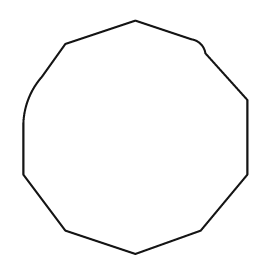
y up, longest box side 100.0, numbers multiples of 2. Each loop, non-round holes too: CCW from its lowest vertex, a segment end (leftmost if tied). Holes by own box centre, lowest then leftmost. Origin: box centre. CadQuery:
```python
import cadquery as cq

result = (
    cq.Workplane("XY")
    .moveTo(0.0, -50.0)
    .lineTo(28.0, -40.0)
    .lineTo(48.0, -16.0)
    .lineTo(48.0, 16.0)
    .lineTo(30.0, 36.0)
    .threePointArc((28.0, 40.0), (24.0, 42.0))
    .lineTo(0.0, 50.0)
    .lineTo(-30.0, 40.0)
    .lineTo(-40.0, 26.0)
    .threePointArc((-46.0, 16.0), (-48.0, 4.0))
    .lineTo(-48.0, -16.0)
    .lineTo(-30.0, -40.0)
    .close()
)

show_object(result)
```